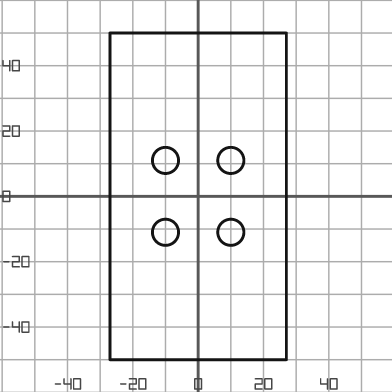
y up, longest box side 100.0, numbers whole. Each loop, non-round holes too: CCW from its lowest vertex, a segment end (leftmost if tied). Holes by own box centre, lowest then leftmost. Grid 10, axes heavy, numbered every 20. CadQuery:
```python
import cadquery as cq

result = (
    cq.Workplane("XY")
    .moveTo(-27.0, -50.0)
    .lineTo(27.0, -50.0)
    .lineTo(27.0, 50.0)
    .lineTo(-27.0, 50.0)
    .close()
    .moveTo(-10.0, -11.0)
    .circle(4.0)
    .moveTo(10.0, -11.0)
    .circle(4.0)
    .moveTo(-10.0, 11.0)
    .circle(4.0)
    .moveTo(10.0, 11.0)
    .circle(4.0)
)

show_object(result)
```